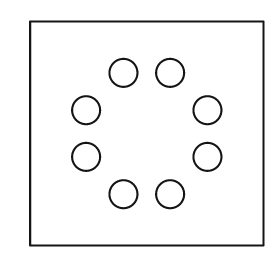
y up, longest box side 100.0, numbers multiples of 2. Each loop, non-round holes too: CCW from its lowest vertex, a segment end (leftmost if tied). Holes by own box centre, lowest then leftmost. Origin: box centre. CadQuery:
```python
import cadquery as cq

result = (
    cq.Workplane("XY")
    .moveTo(-50.0, -48.0)
    .lineTo(50.0, -48.0)
    .lineTo(50.0, 48.0)
    .lineTo(-50.0, 48.0)
    .close()
    .moveTo(-10.0, -26.0)
    .circle(6.0)
    .moveTo(10.0, -26.0)
    .circle(6.0)
    .moveTo(-26.0, -10.0)
    .circle(6.0)
    .moveTo(26.0, -10.0)
    .circle(6.0)
    .moveTo(-26.0, 10.0)
    .circle(6.0)
    .moveTo(26.0, 10.0)
    .circle(6.0)
    .moveTo(-10.0, 26.0)
    .circle(6.0)
    .moveTo(10.0, 26.0)
    .circle(6.0)
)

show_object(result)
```